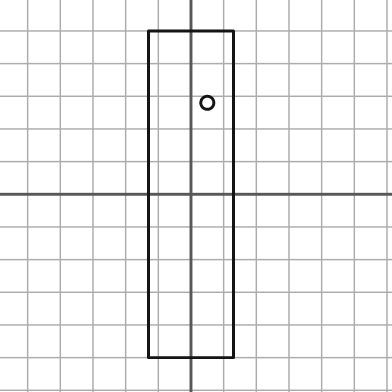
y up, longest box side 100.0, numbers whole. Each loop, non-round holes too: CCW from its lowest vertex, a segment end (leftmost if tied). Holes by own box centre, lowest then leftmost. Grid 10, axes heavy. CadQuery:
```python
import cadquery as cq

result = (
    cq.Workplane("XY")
    .moveTo(-13.0, -50.0)
    .lineTo(13.0, -50.0)
    .lineTo(13.0, 50.0)
    .lineTo(-13.0, 50.0)
    .close()
    .moveTo(5.0, 28.0)
    .circle(2.0)
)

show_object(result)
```